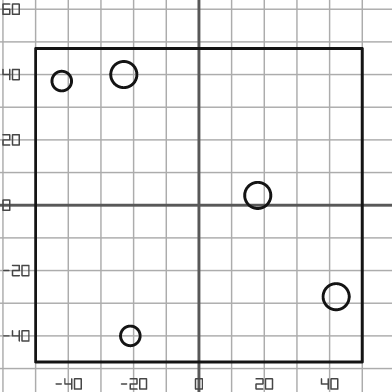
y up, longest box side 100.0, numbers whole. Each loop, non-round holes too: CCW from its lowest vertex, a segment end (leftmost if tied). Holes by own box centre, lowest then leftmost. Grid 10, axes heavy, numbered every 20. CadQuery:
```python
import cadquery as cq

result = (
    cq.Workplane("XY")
    .moveTo(-50.0, -48.0)
    .lineTo(50.0, -48.0)
    .lineTo(50.0, 48.0)
    .lineTo(-50.0, 48.0)
    .close()
    .moveTo(-21.0, -40.0)
    .circle(3.0)
    .moveTo(42.0, -28.0)
    .circle(4.0)
    .moveTo(18.0, 3.0)
    .circle(4.0)
    .moveTo(-42.0, 38.0)
    .circle(3.0)
    .moveTo(-23.0, 40.0)
    .circle(4.0)
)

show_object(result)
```